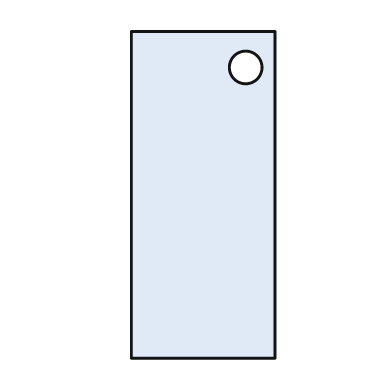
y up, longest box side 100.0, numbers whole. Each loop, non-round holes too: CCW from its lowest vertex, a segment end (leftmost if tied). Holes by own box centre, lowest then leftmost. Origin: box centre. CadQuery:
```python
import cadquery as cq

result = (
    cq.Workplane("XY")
    .moveTo(-22.0, -50.0)
    .lineTo(22.0, -50.0)
    .lineTo(22.0, 50.0)
    .lineTo(-22.0, 50.0)
    .close()
    .moveTo(13.0, 39.0)
    .circle(5.0)
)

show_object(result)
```